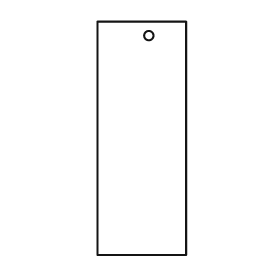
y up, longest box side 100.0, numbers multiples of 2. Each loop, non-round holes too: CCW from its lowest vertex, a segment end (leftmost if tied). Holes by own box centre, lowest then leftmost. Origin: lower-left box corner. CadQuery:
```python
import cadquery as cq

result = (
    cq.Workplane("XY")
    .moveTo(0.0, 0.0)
    .lineTo(38.0, 0.0)
    .lineTo(38.0, 100.0)
    .lineTo(0.0, 100.0)
    .close()
    .moveTo(22.0, 94.0)
    .circle(2.0)
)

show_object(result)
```